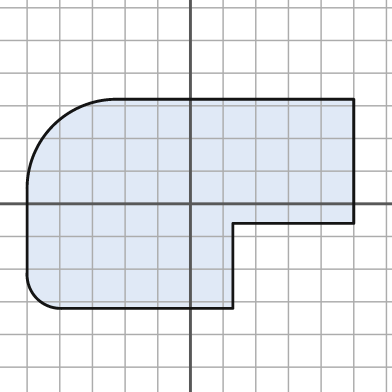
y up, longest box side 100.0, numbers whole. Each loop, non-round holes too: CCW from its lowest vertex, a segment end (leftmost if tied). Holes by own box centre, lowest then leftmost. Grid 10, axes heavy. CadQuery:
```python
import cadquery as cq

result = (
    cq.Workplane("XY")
    .moveTo(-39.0, -32.0)
    .lineTo(13.0, -32.0)
    .lineTo(13.0, -6.0)
    .lineTo(50.0, -6.0)
    .lineTo(50.0, 32.0)
    .lineTo(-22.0, 32.0)
    .threePointArc((-42.0, 24.0), (-50.0, 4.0))
    .lineTo(-50.0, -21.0)
    .threePointArc((-47.0, -29.0), (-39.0, -32.0))
    .close()
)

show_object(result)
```